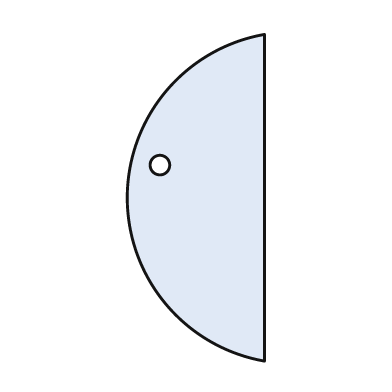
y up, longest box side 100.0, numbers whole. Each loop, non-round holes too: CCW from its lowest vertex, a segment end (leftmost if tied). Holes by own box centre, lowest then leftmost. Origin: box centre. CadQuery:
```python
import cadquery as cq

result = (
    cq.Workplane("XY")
    .moveTo(21.0, -50.0)
    .lineTo(21.0, 50.0)
    .threePointArc((-21.0, 0.0), (21.0, -50.0))
    .close()
    .moveTo(-11.0, 10.0)
    .circle(3.0)
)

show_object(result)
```